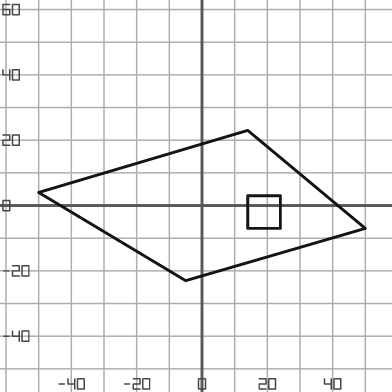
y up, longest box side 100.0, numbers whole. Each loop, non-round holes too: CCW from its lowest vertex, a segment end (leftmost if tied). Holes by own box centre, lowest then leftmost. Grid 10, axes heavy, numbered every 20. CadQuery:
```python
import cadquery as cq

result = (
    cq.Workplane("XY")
    .moveTo(-5.0, -23.0)
    .lineTo(50.0, -7.0)
    .lineTo(14.0, 23.0)
    .lineTo(-50.0, 4.0)
    .close()
    .moveTo(14.0, -7.0)
    .lineTo(24.0, -7.0)
    .lineTo(24.0, 3.0)
    .lineTo(14.0, 3.0)
    .close()
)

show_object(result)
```